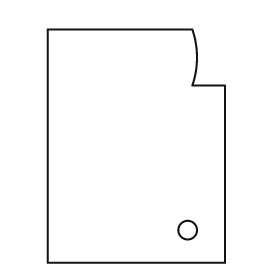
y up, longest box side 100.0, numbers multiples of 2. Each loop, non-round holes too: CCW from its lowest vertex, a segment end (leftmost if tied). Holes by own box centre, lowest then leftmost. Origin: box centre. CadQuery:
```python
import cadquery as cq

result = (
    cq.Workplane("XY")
    .moveTo(-38.0, -50.0)
    .lineTo(38.0, -50.0)
    .lineTo(38.0, 26.0)
    .lineTo(24.0, 26.0)
    .threePointArc((26.0, 38.0), (24.0, 50.0))
    .lineTo(-38.0, 50.0)
    .close()
    .moveTo(22.0, -36.0)
    .circle(4.0)
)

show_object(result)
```